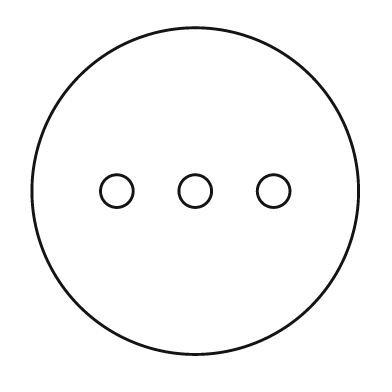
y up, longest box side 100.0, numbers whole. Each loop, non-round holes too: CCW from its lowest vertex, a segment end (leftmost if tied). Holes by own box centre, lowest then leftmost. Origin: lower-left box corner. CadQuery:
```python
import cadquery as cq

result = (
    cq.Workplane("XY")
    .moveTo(50.0, 50.0)
    .circle(50.0)
    .moveTo(26.0, 50.0)
    .circle(5.0)
    .moveTo(50.0, 50.0)
    .circle(5.0)
    .moveTo(74.0, 50.0)
    .circle(5.0)
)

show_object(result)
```